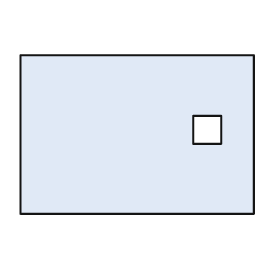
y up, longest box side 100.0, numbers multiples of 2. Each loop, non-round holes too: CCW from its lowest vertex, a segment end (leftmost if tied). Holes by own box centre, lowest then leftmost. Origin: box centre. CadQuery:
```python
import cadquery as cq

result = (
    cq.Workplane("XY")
    .moveTo(-50.0, -34.0)
    .lineTo(50.0, -34.0)
    .lineTo(50.0, 34.0)
    .lineTo(-50.0, 34.0)
    .close()
    .moveTo(24.0, -4.0)
    .lineTo(36.0, -4.0)
    .lineTo(36.0, 8.0)
    .lineTo(24.0, 8.0)
    .close()
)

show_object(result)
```